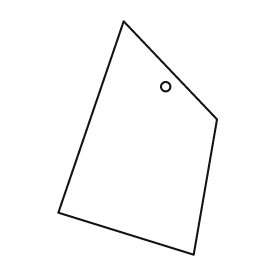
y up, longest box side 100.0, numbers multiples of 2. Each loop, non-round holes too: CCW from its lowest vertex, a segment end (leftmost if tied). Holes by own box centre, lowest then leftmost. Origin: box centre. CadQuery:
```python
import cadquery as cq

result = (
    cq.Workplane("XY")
    .moveTo(24.0, -50.0)
    .lineTo(34.0, 8.0)
    .lineTo(-6.0, 50.0)
    .lineTo(-34.0, -32.0)
    .close()
    .moveTo(12.0, 22.0)
    .circle(2.0)
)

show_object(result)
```